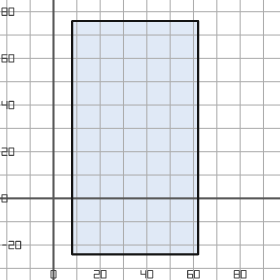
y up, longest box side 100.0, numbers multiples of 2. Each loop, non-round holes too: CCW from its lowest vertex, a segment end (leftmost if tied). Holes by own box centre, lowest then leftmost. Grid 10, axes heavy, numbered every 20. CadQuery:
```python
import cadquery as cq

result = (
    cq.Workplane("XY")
    .moveTo(8.0, -24.0)
    .lineTo(62.0, -24.0)
    .lineTo(62.0, 76.0)
    .lineTo(8.0, 76.0)
    .close()
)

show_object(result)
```